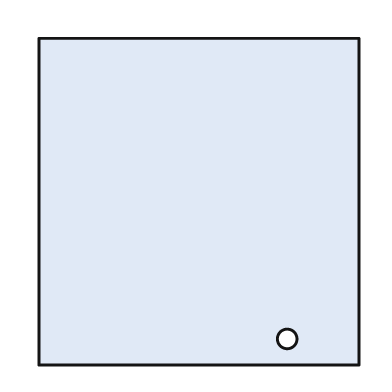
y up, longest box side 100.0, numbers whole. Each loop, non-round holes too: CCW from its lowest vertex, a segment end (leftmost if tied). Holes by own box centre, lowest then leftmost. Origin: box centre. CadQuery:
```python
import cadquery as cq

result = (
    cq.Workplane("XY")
    .moveTo(-49.0, -50.0)
    .lineTo(49.0, -50.0)
    .lineTo(49.0, 50.0)
    .lineTo(-49.0, 50.0)
    .close()
    .moveTo(27.0, -42.0)
    .circle(3.0)
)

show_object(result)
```